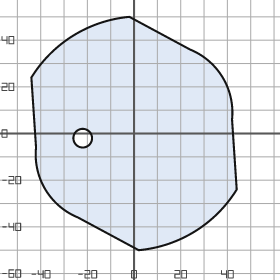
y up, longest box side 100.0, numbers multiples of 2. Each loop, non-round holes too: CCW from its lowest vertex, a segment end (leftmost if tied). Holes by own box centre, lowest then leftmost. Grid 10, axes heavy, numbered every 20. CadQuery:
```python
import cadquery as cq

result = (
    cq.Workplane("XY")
    .moveTo(2.0, -50.0)
    .threePointArc((26.0, -42.0), (44.0, -24.0))
    .lineTo(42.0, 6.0)
    .threePointArc((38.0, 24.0), (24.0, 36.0))
    .lineTo(-2.0, 50.0)
    .threePointArc((-26.0, 42.0), (-44.0, 24.0))
    .lineTo(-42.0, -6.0)
    .threePointArc((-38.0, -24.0), (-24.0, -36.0))
    .close()
    .moveTo(-22.0, -2.0)
    .circle(4.0)
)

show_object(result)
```